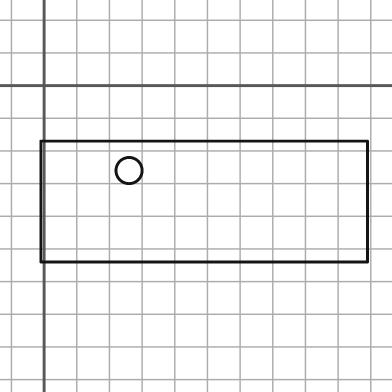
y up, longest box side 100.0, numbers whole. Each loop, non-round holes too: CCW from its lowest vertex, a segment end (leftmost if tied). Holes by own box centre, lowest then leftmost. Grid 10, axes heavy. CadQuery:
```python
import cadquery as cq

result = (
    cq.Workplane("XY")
    .moveTo(-1.0, -54.0)
    .lineTo(99.0, -54.0)
    .lineTo(99.0, -17.0)
    .lineTo(-1.0, -17.0)
    .close()
    .moveTo(26.0, -26.0)
    .circle(4.0)
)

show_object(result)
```